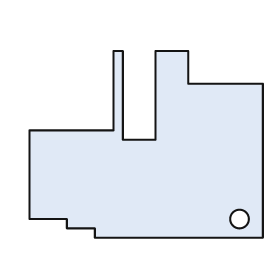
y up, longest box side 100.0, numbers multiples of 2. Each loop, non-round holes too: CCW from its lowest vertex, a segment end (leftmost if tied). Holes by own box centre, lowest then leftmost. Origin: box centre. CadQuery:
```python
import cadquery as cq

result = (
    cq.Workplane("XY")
    .moveTo(-22.0, -40.0)
    .lineTo(50.0, -40.0)
    .lineTo(50.0, 26.0)
    .lineTo(18.0, 26.0)
    .lineTo(18.0, 40.0)
    .lineTo(4.0, 40.0)
    .lineTo(4.0, 2.0)
    .lineTo(-10.0, 2.0)
    .lineTo(-10.0, 40.0)
    .lineTo(-14.0, 40.0)
    .lineTo(-14.0, 6.0)
    .lineTo(-50.0, 6.0)
    .lineTo(-50.0, -32.0)
    .lineTo(-34.0, -32.0)
    .lineTo(-34.0, -36.0)
    .lineTo(-22.0, -36.0)
    .close()
    .moveTo(40.0, -32.0)
    .circle(4.0)
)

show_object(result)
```